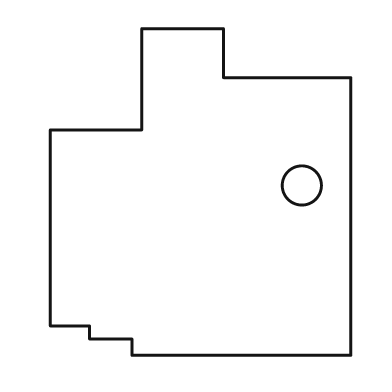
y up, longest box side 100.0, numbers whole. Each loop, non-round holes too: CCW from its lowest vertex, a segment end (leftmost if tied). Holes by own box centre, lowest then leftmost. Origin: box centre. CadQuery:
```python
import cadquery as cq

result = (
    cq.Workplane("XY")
    .moveTo(-21.0, -50.0)
    .lineTo(46.0, -50.0)
    .lineTo(46.0, 35.0)
    .lineTo(7.0, 35.0)
    .lineTo(7.0, 50.0)
    .lineTo(-18.0, 50.0)
    .lineTo(-18.0, 19.0)
    .lineTo(-46.0, 19.0)
    .lineTo(-46.0, -41.0)
    .lineTo(-34.0, -41.0)
    .lineTo(-34.0, -45.0)
    .lineTo(-21.0, -45.0)
    .close()
    .moveTo(31.0, 2.0)
    .circle(6.0)
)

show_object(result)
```